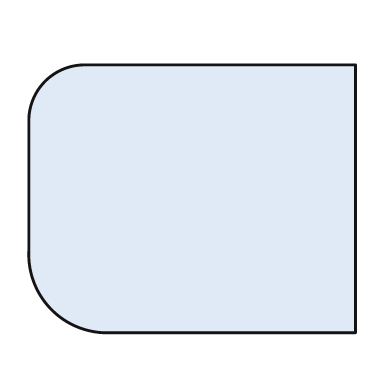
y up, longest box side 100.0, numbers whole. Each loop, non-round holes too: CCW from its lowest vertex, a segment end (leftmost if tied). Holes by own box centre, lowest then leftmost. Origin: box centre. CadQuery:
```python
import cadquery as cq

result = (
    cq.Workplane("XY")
    .moveTo(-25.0, -41.0)
    .lineTo(50.0, -41.0)
    .lineTo(50.0, 41.0)
    .lineTo(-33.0, 41.0)
    .threePointArc((-45.0, 36.0), (-50.0, 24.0))
    .lineTo(-50.0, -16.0)
    .threePointArc((-43.0, -34.0), (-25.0, -41.0))
    .close()
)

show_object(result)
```